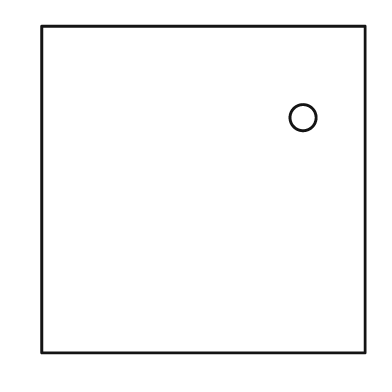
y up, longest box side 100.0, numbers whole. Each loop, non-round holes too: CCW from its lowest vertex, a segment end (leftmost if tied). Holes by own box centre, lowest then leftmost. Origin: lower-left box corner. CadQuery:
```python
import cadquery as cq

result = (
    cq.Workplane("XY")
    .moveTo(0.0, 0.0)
    .lineTo(99.0, 0.0)
    .lineTo(99.0, 100.0)
    .lineTo(0.0, 100.0)
    .close()
    .moveTo(80.0, 72.0)
    .circle(4.0)
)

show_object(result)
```